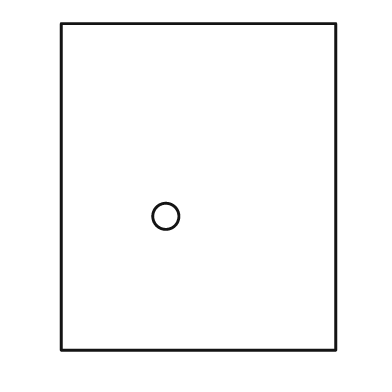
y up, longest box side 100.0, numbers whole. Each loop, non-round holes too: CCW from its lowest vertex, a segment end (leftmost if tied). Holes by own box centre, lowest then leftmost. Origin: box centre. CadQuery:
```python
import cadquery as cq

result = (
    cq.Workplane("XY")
    .moveTo(-42.0, -50.0)
    .lineTo(42.0, -50.0)
    .lineTo(42.0, 50.0)
    .lineTo(-42.0, 50.0)
    .close()
    .moveTo(-10.0, -9.0)
    .circle(4.0)
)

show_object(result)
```